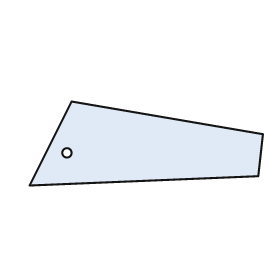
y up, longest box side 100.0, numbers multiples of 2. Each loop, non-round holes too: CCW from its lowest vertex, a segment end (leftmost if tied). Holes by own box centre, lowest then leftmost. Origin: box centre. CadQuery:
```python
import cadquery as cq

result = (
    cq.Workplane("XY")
    .moveTo(-50.0, -18.0)
    .lineTo(48.0, -14.0)
    .lineTo(50.0, 4.0)
    .lineTo(-32.0, 18.0)
    .close()
    .moveTo(-34.0, -4.0)
    .circle(2.0)
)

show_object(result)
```